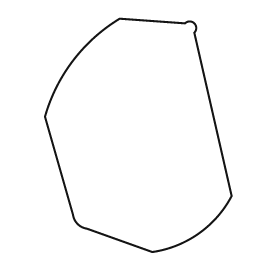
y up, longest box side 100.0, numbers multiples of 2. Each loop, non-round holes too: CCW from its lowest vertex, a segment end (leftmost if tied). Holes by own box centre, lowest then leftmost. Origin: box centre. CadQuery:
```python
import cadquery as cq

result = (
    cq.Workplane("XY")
    .moveTo(6.0, -50.0)
    .threePointArc((26.0, -42.0), (40.0, -26.0))
    .lineTo(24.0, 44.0)
    .threePointArc((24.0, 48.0), (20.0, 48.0))
    .lineTo(-8.0, 50.0)
    .threePointArc((-28.0, 32.0), (-40.0, 8.0))
    .lineTo(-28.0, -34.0)
    .threePointArc((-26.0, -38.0), (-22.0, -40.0))
    .close()
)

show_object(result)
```